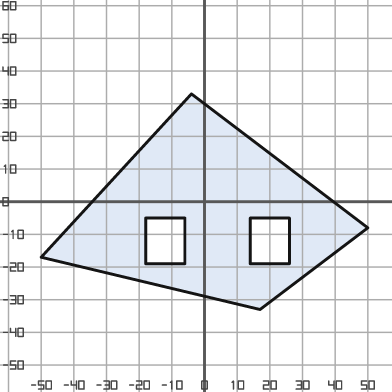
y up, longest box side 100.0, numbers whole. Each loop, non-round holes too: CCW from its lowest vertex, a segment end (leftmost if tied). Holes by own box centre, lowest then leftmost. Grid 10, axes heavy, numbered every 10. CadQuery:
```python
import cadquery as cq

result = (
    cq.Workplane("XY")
    .moveTo(17.0, -33.0)
    .lineTo(50.0, -8.0)
    .lineTo(-4.0, 33.0)
    .lineTo(-50.0, -17.0)
    .close()
    .moveTo(-18.0, -19.0)
    .lineTo(-6.0, -19.0)
    .lineTo(-6.0, -5.0)
    .lineTo(-18.0, -5.0)
    .close()
    .moveTo(14.0, -19.0)
    .lineTo(26.0, -19.0)
    .lineTo(26.0, -5.0)
    .lineTo(14.0, -5.0)
    .close()
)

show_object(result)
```